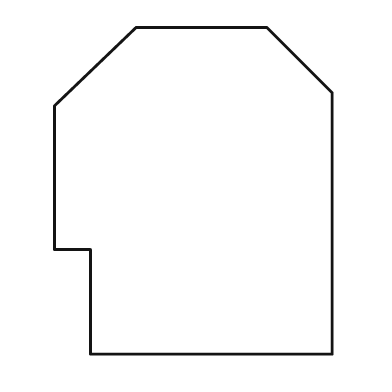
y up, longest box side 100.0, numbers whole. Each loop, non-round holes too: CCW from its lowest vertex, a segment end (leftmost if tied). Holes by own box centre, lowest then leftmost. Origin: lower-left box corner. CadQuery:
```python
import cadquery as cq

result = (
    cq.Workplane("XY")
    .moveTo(11.0, 0.0)
    .lineTo(85.0, 0.0)
    .lineTo(85.0, 80.0)
    .lineTo(65.0, 100.0)
    .lineTo(25.0, 100.0)
    .lineTo(0.0, 76.0)
    .lineTo(0.0, 32.0)
    .lineTo(11.0, 32.0)
    .close()
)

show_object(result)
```